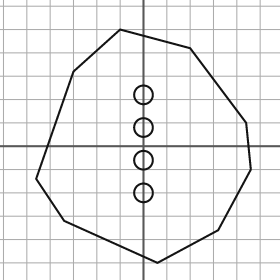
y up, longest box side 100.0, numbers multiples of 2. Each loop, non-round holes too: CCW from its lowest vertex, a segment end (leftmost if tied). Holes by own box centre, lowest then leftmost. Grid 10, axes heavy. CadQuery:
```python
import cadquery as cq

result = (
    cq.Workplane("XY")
    .moveTo(6.0, -50.0)
    .lineTo(32.0, -36.0)
    .lineTo(46.0, -10.0)
    .lineTo(44.0, 10.0)
    .lineTo(20.0, 42.0)
    .lineTo(-10.0, 50.0)
    .lineTo(-30.0, 32.0)
    .lineTo(-46.0, -14.0)
    .lineTo(-34.0, -32.0)
    .close()
    .moveTo(0.0, -20.0)
    .circle(4.0)
    .moveTo(0.0, -6.0)
    .circle(4.0)
    .moveTo(0.0, 8.0)
    .circle(4.0)
    .moveTo(0.0, 22.0)
    .circle(4.0)
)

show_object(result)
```